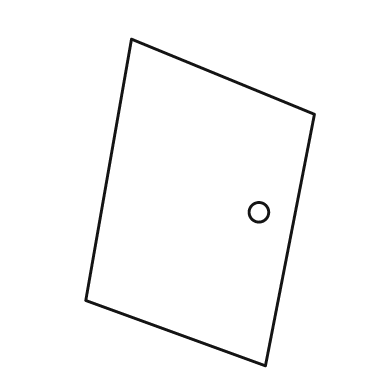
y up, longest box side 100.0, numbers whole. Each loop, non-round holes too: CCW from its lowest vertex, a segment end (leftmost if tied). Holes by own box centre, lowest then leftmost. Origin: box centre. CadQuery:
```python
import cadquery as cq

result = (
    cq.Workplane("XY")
    .moveTo(20.0, -50.0)
    .lineTo(35.0, 27.0)
    .lineTo(-21.0, 50.0)
    .lineTo(-35.0, -30.0)
    .close()
    .moveTo(18.0, -3.0)
    .circle(3.0)
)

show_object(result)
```